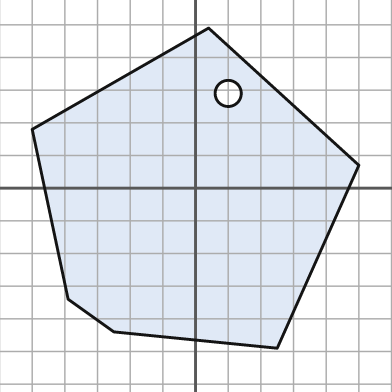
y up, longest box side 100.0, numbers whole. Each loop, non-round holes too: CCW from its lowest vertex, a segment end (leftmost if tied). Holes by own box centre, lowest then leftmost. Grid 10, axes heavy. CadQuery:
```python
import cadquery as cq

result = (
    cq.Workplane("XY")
    .moveTo(25.0, -49.0)
    .lineTo(50.0, 7.0)
    .lineTo(4.0, 49.0)
    .lineTo(-50.0, 18.0)
    .lineTo(-39.0, -34.0)
    .lineTo(-25.0, -44.0)
    .close()
    .moveTo(10.0, 29.0)
    .circle(4.0)
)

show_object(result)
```